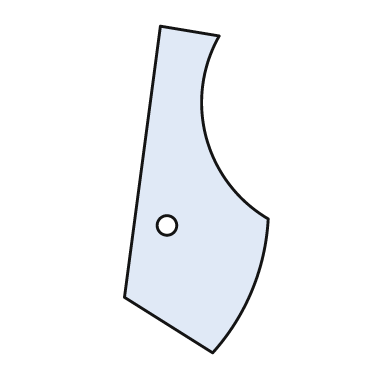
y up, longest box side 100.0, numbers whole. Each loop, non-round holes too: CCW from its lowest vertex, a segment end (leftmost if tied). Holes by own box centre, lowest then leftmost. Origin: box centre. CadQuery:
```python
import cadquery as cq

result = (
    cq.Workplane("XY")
    .moveTo(5.0, -50.0)
    .threePointArc((17.0, -31.0), (22.0, -9.0))
    .threePointArc((3.0, 16.0), (7.0, 47.0))
    .lineTo(-11.0, 50.0)
    .lineTo(-22.0, -33.0)
    .close()
    .moveTo(-9.0, -11.0)
    .circle(3.0)
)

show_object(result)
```